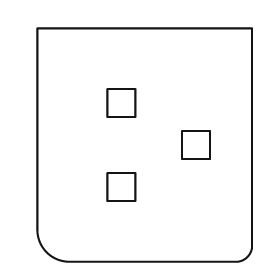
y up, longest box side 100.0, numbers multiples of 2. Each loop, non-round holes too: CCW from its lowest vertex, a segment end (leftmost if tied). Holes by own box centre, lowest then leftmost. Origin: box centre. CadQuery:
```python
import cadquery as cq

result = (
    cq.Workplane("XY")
    .moveTo(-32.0, -50.0)
    .lineTo(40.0, -50.0)
    .threePointArc((44.0, -48.0), (46.0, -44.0))
    .lineTo(46.0, 50.0)
    .lineTo(-46.0, 50.0)
    .lineTo(-46.0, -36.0)
    .threePointArc((-42.0, -46.0), (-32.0, -50.0))
    .close()
    .moveTo(-16.0, -24.0)
    .lineTo(-4.0, -24.0)
    .lineTo(-4.0, -12.0)
    .lineTo(-16.0, -12.0)
    .close()
    .moveTo(16.0, -6.0)
    .lineTo(28.0, -6.0)
    .lineTo(28.0, 6.0)
    .lineTo(16.0, 6.0)
    .close()
    .moveTo(-16.0, 12.0)
    .lineTo(-4.0, 12.0)
    .lineTo(-4.0, 24.0)
    .lineTo(-16.0, 24.0)
    .close()
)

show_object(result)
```